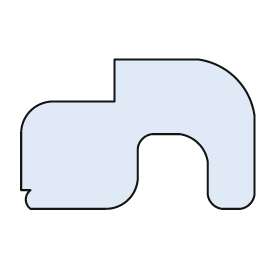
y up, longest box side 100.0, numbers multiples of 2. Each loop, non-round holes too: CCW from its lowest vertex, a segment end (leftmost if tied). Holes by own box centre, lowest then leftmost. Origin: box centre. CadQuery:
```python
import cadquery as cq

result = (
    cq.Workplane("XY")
    .moveTo(-46.0, -32.0)
    .lineTo(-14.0, -32.0)
    .threePointArc((-4.0, -28.0), (0.0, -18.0))
    .lineTo(0.0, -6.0)
    .threePointArc((2.0, -2.0), (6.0, 0.0))
    .lineTo(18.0, 0.0)
    .threePointArc((26.0, -4.0), (30.0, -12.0))
    .lineTo(30.0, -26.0)
    .threePointArc((32.0, -30.0), (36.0, -32.0))
    .lineTo(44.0, -32.0)
    .threePointArc((48.0, -30.0), (50.0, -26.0))
    .lineTo(50.0, 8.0)
    .threePointArc((42.0, 24.0), (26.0, 32.0))
    .lineTo(-10.0, 32.0)
    .lineTo(-10.0, 14.0)
    .lineTo(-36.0, 14.0)
    .threePointArc((-46.0, 10.0), (-50.0, 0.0))
    .lineTo(-50.0, -24.0)
    .lineTo(-46.0, -24.0)
    .threePointArc((-48.0, -28.0), (-46.0, -32.0))
    .close()
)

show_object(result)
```